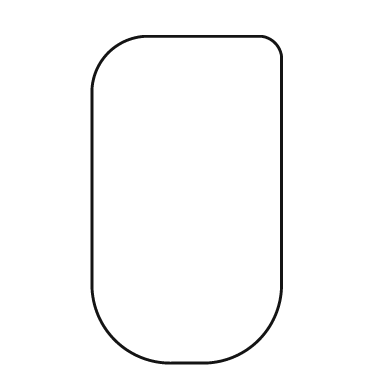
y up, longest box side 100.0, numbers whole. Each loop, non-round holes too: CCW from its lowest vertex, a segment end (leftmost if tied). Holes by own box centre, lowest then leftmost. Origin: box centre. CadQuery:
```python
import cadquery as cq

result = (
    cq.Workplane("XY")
    .moveTo(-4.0, -50.0)
    .lineTo(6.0, -50.0)
    .threePointArc((22.0, -43.0), (29.0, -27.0))
    .lineTo(29.0, 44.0)
    .threePointArc((27.0, 48.0), (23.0, 50.0))
    .lineTo(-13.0, 50.0)
    .threePointArc((-24.0, 45.0), (-29.0, 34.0))
    .lineTo(-29.0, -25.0)
    .threePointArc((-22.0, -43.0), (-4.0, -50.0))
    .close()
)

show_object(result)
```